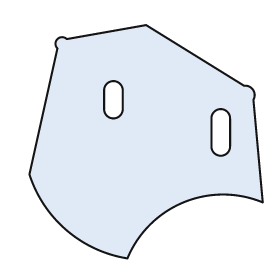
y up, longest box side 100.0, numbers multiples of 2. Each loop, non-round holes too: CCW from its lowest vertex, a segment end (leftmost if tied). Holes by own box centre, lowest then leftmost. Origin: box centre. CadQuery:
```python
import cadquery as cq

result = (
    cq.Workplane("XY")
    .moveTo(-8.0, -50.0)
    .threePointArc((16.0, -26.0), (50.0, -26.0))
    .lineTo(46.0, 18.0)
    .threePointArc((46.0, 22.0), (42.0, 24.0))
    .lineTo(0.0, 50.0)
    .lineTo(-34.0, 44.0)
    .threePointArc((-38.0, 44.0), (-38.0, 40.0))
    .lineTo(-50.0, -14.0)
    .threePointArc((-34.0, -38.0), (-8.0, -50.0))
    .close()
    .moveTo(28.0, -2.0)
    .threePointArc((32.0, -6.0), (36.0, -2.0))
    .lineTo(36.0, 10.0)
    .threePointArc((32.0, 14.0), (28.0, 10.0))
    .close()
    .moveTo(-18.0, 14.0)
    .threePointArc((-14.0, 10.0), (-10.0, 14.0))
    .lineTo(-10.0, 22.0)
    .threePointArc((-14.0, 26.0), (-18.0, 22.0))
    .close()
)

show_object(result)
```